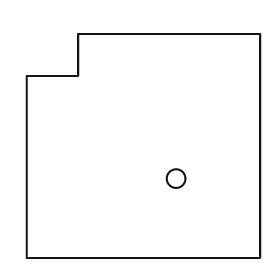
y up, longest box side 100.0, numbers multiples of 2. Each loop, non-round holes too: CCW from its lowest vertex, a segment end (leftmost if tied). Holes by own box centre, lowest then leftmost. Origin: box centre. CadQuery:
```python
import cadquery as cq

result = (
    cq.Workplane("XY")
    .moveTo(-50.0, -48.0)
    .lineTo(50.0, -48.0)
    .lineTo(50.0, 48.0)
    .lineTo(-28.0, 48.0)
    .lineTo(-28.0, 30.0)
    .lineTo(-50.0, 30.0)
    .close()
    .moveTo(14.0, -14.0)
    .circle(4.0)
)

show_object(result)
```